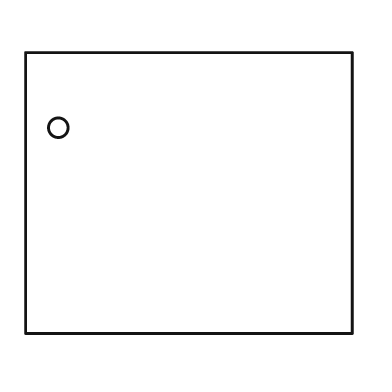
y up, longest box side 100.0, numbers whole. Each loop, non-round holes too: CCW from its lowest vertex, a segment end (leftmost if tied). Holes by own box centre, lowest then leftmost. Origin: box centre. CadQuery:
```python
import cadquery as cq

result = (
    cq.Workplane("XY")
    .moveTo(-50.0, -43.0)
    .lineTo(50.0, -43.0)
    .lineTo(50.0, 43.0)
    .lineTo(-50.0, 43.0)
    .close()
    .moveTo(-40.0, 20.0)
    .circle(3.0)
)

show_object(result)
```